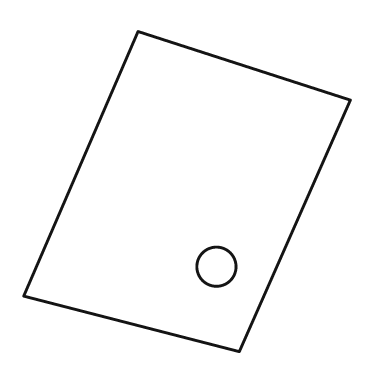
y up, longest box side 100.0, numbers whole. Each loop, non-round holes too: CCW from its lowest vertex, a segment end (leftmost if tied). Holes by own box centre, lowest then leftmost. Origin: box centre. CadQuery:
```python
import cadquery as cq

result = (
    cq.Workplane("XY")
    .moveTo(16.0, -49.0)
    .lineTo(50.0, 28.0)
    .lineTo(-15.0, 49.0)
    .lineTo(-50.0, -32.0)
    .close()
    .moveTo(9.0, -23.0)
    .circle(6.0)
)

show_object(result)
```